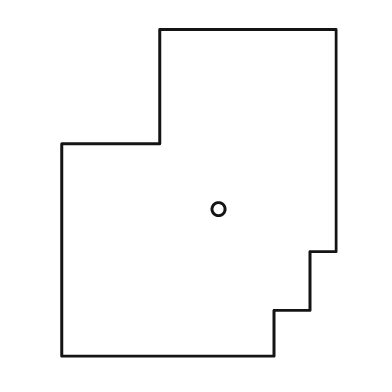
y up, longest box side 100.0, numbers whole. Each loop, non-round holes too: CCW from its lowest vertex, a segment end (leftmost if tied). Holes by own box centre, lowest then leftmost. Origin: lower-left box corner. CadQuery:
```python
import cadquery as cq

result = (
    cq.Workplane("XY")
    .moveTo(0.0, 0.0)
    .lineTo(65.0, 0.0)
    .lineTo(65.0, 14.0)
    .lineTo(76.0, 14.0)
    .lineTo(76.0, 32.0)
    .lineTo(84.0, 32.0)
    .lineTo(84.0, 100.0)
    .lineTo(30.0, 100.0)
    .lineTo(30.0, 65.0)
    .lineTo(0.0, 65.0)
    .close()
    .moveTo(48.0, 45.0)
    .circle(2.0)
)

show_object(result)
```